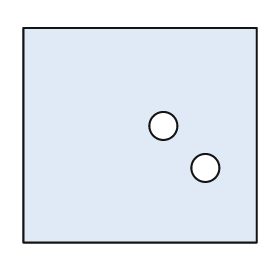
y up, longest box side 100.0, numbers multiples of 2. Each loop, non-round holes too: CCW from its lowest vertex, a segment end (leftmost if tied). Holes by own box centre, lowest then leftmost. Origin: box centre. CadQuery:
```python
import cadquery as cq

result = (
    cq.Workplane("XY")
    .moveTo(-50.0, -46.0)
    .lineTo(50.0, -46.0)
    .lineTo(50.0, 46.0)
    .lineTo(-50.0, 46.0)
    .close()
    .moveTo(28.0, -14.0)
    .circle(6.0)
    .moveTo(10.0, 4.0)
    .circle(6.0)
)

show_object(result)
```